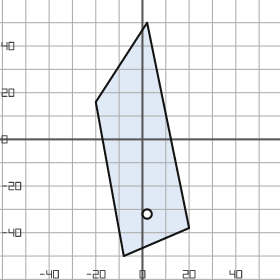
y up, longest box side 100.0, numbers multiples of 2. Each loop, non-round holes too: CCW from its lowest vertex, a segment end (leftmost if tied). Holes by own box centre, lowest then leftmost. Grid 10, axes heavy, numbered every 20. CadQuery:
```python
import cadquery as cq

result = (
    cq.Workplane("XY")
    .moveTo(-8.0, -50.0)
    .lineTo(20.0, -38.0)
    .lineTo(2.0, 50.0)
    .lineTo(-20.0, 16.0)
    .close()
    .moveTo(2.0, -32.0)
    .circle(2.0)
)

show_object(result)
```